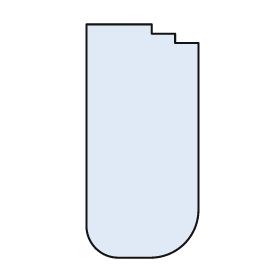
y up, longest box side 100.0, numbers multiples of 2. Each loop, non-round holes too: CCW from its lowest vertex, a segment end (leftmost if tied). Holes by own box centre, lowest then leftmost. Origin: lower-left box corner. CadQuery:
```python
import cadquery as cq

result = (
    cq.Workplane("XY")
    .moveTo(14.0, 0.0)
    .lineTo(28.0, 0.0)
    .threePointArc((42.0, 6.0), (48.0, 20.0))
    .lineTo(48.0, 92.0)
    .lineTo(38.0, 92.0)
    .lineTo(38.0, 96.0)
    .lineTo(28.0, 96.0)
    .lineTo(28.0, 100.0)
    .lineTo(0.0, 100.0)
    .lineTo(0.0, 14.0)
    .threePointArc((4.0, 4.0), (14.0, 0.0))
    .close()
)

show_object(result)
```